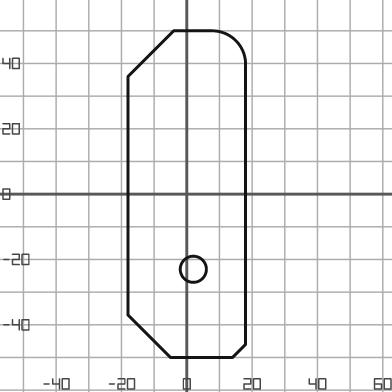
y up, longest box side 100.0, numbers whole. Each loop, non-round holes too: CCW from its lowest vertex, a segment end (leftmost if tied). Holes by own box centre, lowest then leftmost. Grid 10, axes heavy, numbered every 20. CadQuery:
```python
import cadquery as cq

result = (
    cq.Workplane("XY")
    .moveTo(-5.0, -50.0)
    .lineTo(14.0, -50.0)
    .lineTo(18.0, -46.0)
    .lineTo(18.0, 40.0)
    .threePointArc((15.0, 47.0), (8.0, 50.0))
    .lineTo(-4.0, 50.0)
    .lineTo(-18.0, 36.0)
    .lineTo(-18.0, -37.0)
    .close()
    .moveTo(2.0, -23.0)
    .circle(4.0)
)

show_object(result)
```